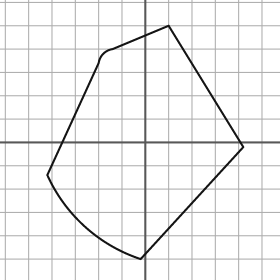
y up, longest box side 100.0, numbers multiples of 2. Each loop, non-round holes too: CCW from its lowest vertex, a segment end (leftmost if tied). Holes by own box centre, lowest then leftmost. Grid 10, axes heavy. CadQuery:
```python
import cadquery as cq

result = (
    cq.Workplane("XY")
    .moveTo(-2.0, -50.0)
    .lineTo(42.0, -2.0)
    .lineTo(10.0, 50.0)
    .lineTo(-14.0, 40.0)
    .threePointArc((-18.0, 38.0), (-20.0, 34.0))
    .lineTo(-42.0, -14.0)
    .threePointArc((-26.0, -36.0), (-2.0, -50.0))
    .close()
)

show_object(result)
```